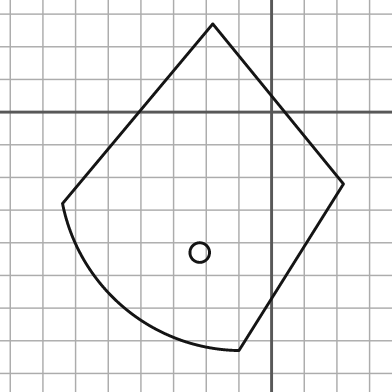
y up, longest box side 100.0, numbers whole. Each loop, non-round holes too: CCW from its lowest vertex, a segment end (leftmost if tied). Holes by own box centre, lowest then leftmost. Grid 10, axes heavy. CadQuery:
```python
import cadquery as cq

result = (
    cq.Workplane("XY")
    .moveTo(-10.0, -73.0)
    .lineTo(22.0, -22.0)
    .lineTo(-18.0, 27.0)
    .lineTo(-64.0, -28.0)
    .threePointArc((-45.0, -60.0), (-10.0, -73.0))
    .close()
    .moveTo(-22.0, -43.0)
    .circle(3.0)
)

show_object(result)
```